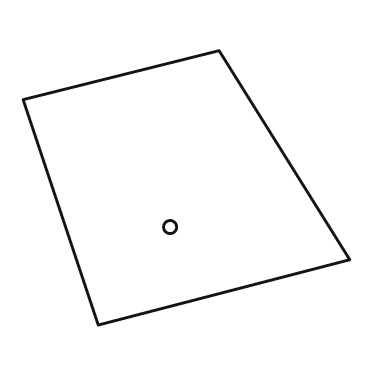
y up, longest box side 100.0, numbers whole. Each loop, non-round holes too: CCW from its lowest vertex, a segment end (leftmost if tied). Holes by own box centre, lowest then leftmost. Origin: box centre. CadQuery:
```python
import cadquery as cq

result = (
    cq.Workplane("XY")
    .moveTo(-27.0, -42.0)
    .lineTo(50.0, -22.0)
    .lineTo(10.0, 42.0)
    .lineTo(-50.0, 27.0)
    .close()
    .moveTo(-5.0, -12.0)
    .circle(2.0)
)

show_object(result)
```